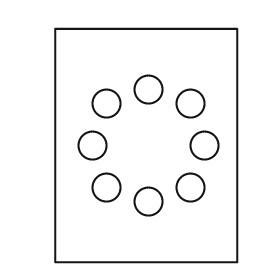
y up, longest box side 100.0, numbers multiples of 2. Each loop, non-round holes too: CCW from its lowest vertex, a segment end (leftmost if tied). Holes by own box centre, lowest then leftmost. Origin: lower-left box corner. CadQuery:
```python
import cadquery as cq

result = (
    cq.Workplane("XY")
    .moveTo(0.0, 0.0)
    .lineTo(78.0, 0.0)
    .lineTo(78.0, 100.0)
    .lineTo(0.0, 100.0)
    .close()
    .moveTo(40.0, 26.0)
    .circle(6.0)
    .moveTo(22.0, 32.0)
    .circle(6.0)
    .moveTo(58.0, 32.0)
    .circle(6.0)
    .moveTo(16.0, 50.0)
    .circle(6.0)
    .moveTo(64.0, 50.0)
    .circle(6.0)
    .moveTo(22.0, 68.0)
    .circle(6.0)
    .moveTo(58.0, 68.0)
    .circle(6.0)
    .moveTo(40.0, 74.0)
    .circle(6.0)
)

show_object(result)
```